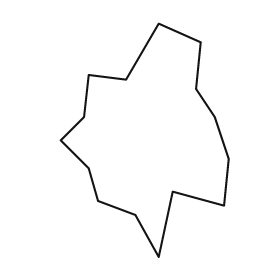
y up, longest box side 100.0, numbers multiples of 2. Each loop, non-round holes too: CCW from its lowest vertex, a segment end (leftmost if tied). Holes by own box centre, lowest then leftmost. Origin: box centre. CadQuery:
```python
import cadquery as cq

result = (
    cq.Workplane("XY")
    .moveTo(6.0, -50.0)
    .lineTo(12.0, -22.0)
    .lineTo(34.0, -28.0)
    .lineTo(36.0, -8.0)
    .lineTo(30.0, 10.0)
    .lineTo(22.0, 22.0)
    .lineTo(24.0, 42.0)
    .lineTo(6.0, 50.0)
    .lineTo(-8.0, 26.0)
    .lineTo(-24.0, 28.0)
    .lineTo(-26.0, 10.0)
    .lineTo(-36.0, 0.0)
    .lineTo(-24.0, -12.0)
    .lineTo(-20.0, -26.0)
    .lineTo(-4.0, -32.0)
    .close()
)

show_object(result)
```